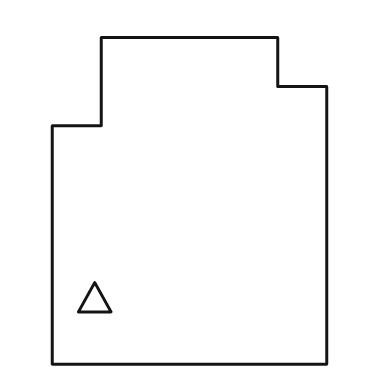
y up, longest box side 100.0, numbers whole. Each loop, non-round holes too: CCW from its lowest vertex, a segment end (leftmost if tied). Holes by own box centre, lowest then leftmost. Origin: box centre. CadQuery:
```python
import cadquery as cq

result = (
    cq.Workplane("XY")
    .moveTo(-42.0, -50.0)
    .lineTo(42.0, -50.0)
    .lineTo(42.0, 35.0)
    .lineTo(27.0, 35.0)
    .lineTo(27.0, 50.0)
    .lineTo(-27.0, 50.0)
    .lineTo(-27.0, 23.0)
    .lineTo(-42.0, 23.0)
    .close()
    .moveTo(-34.0, -34.0)
    .lineTo(-24.0, -34.0)
    .lineTo(-29.0, -25.0)
    .close()
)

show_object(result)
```